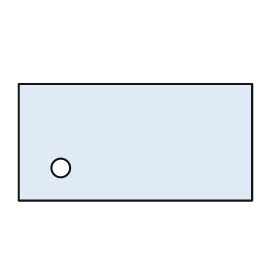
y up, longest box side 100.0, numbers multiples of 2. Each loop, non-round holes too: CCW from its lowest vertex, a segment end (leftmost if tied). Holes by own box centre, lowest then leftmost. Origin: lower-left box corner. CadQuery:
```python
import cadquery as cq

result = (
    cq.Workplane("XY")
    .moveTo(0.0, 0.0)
    .lineTo(100.0, 0.0)
    .lineTo(100.0, 50.0)
    .lineTo(0.0, 50.0)
    .close()
    .moveTo(18.0, 14.0)
    .circle(4.0)
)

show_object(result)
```